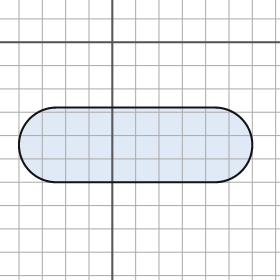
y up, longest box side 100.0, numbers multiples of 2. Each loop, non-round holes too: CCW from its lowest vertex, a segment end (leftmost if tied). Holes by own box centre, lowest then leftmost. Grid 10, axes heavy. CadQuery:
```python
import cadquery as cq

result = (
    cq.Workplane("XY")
    .moveTo(-24.0, -60.0)
    .lineTo(44.0, -60.0)
    .threePointArc((60.0, -44.0), (44.0, -28.0))
    .lineTo(-24.0, -28.0)
    .threePointArc((-40.0, -44.0), (-24.0, -60.0))
    .close()
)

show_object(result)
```